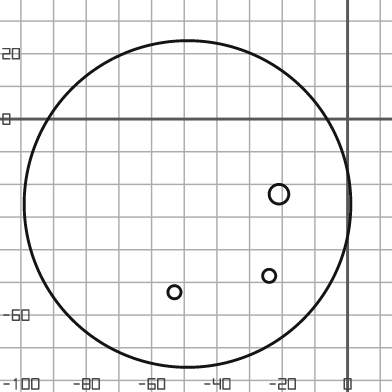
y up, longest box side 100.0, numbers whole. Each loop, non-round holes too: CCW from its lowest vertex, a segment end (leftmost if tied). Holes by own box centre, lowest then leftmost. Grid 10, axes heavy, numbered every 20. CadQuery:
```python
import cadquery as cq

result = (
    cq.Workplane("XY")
    .moveTo(-49.0, -26.0)
    .circle(50.0)
    .moveTo(-53.0, -53.0)
    .circle(2.0)
    .moveTo(-24.0, -48.0)
    .circle(2.0)
    .moveTo(-21.0, -23.0)
    .circle(3.0)
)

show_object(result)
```